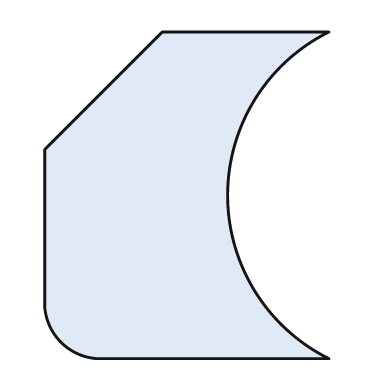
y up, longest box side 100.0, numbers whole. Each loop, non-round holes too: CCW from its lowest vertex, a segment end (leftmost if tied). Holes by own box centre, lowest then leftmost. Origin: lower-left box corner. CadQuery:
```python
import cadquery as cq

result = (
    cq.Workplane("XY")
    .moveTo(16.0, 0.0)
    .lineTo(87.0, 0.0)
    .threePointArc((56.0, 50.0), (87.0, 100.0))
    .lineTo(36.0, 100.0)
    .lineTo(0.0, 64.0)
    .lineTo(0.0, 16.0)
    .threePointArc((5.0, 5.0), (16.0, 0.0))
    .close()
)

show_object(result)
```